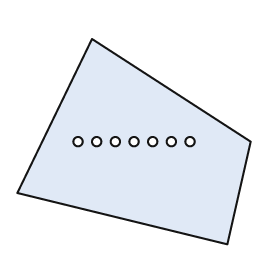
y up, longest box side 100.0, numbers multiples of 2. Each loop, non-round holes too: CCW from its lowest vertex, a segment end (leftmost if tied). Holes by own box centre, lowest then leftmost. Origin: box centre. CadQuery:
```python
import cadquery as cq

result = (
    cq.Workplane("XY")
    .moveTo(40.0, -44.0)
    .lineTo(50.0, 0.0)
    .lineTo(-18.0, 44.0)
    .lineTo(-50.0, -22.0)
    .close()
    .moveTo(-24.0, 0.0)
    .circle(2.0)
    .moveTo(-16.0, 0.0)
    .circle(2.0)
    .moveTo(-8.0, 0.0)
    .circle(2.0)
    .moveTo(0.0, 0.0)
    .circle(2.0)
    .moveTo(8.0, 0.0)
    .circle(2.0)
    .moveTo(16.0, 0.0)
    .circle(2.0)
    .moveTo(24.0, 0.0)
    .circle(2.0)
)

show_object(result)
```